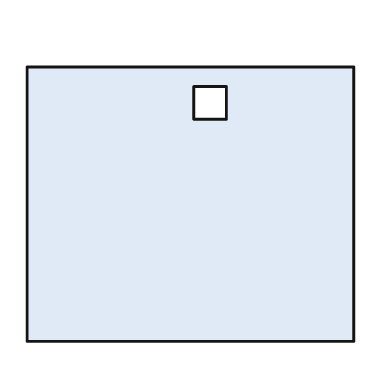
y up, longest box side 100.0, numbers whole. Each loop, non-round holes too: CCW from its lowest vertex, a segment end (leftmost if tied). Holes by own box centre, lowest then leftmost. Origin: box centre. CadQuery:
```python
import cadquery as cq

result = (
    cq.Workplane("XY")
    .moveTo(-50.0, -42.0)
    .lineTo(50.0, -42.0)
    .lineTo(50.0, 42.0)
    .lineTo(-50.0, 42.0)
    .close()
    .moveTo(1.0, 26.0)
    .lineTo(11.0, 26.0)
    .lineTo(11.0, 36.0)
    .lineTo(1.0, 36.0)
    .close()
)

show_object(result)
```